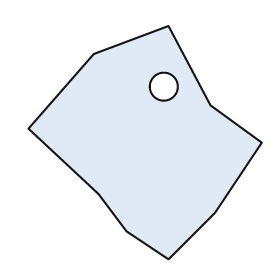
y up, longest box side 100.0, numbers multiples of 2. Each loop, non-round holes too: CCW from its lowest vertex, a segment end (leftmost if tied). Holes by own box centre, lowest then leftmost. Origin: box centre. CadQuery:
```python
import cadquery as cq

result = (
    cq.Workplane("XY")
    .moveTo(10.0, -50.0)
    .lineTo(30.0, -30.0)
    .lineTo(50.0, 0.0)
    .lineTo(28.0, 16.0)
    .lineTo(10.0, 50.0)
    .lineTo(-22.0, 38.0)
    .lineTo(-50.0, 6.0)
    .lineTo(-20.0, -22.0)
    .lineTo(-8.0, -38.0)
    .close()
    .moveTo(8.0, 24.0)
    .circle(6.0)
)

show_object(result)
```